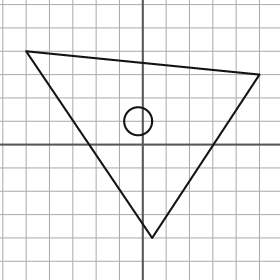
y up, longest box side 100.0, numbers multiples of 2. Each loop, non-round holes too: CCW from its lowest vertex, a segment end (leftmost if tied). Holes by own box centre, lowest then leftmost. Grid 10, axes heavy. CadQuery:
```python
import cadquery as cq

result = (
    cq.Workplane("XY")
    .moveTo(4.0, -40.0)
    .lineTo(50.0, 30.0)
    .lineTo(-50.0, 40.0)
    .close()
    .moveTo(-2.0, 10.0)
    .circle(6.0)
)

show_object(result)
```